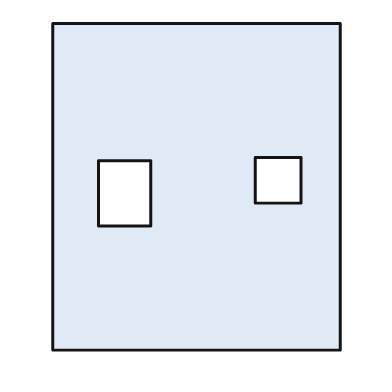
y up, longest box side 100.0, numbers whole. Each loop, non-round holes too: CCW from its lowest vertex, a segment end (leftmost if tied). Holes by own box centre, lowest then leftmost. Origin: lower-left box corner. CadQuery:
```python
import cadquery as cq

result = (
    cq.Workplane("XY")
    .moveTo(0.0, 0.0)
    .lineTo(88.0, 0.0)
    .lineTo(88.0, 100.0)
    .lineTo(0.0, 100.0)
    .close()
    .moveTo(14.0, 38.0)
    .lineTo(30.0, 38.0)
    .lineTo(30.0, 58.0)
    .lineTo(14.0, 58.0)
    .close()
    .moveTo(62.0, 45.0)
    .lineTo(76.0, 45.0)
    .lineTo(76.0, 59.0)
    .lineTo(62.0, 59.0)
    .close()
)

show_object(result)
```